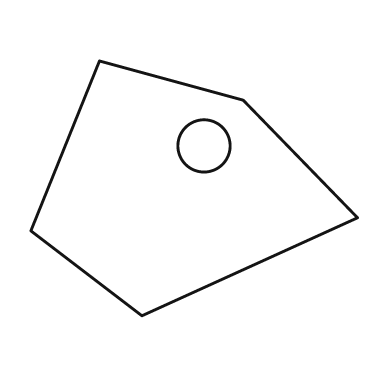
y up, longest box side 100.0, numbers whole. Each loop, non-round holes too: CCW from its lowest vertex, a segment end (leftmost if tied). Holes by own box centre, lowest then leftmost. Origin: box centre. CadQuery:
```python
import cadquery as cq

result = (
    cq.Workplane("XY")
    .moveTo(-16.0, -39.0)
    .lineTo(50.0, -9.0)
    .lineTo(15.0, 27.0)
    .lineTo(-29.0, 39.0)
    .lineTo(-50.0, -13.0)
    .close()
    .moveTo(3.0, 13.0)
    .circle(8.0)
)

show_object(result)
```